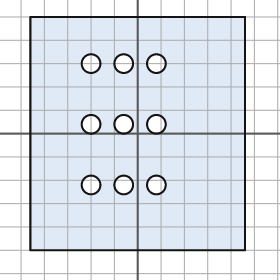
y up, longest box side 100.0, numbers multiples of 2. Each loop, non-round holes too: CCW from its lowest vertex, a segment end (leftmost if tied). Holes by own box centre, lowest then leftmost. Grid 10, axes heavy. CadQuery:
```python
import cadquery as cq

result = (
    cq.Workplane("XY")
    .moveTo(-46.0, -50.0)
    .lineTo(46.0, -50.0)
    .lineTo(46.0, 50.0)
    .lineTo(-46.0, 50.0)
    .close()
    .moveTo(-20.0, -22.0)
    .circle(4.0)
    .moveTo(-6.0, -22.0)
    .circle(4.0)
    .moveTo(8.0, -22.0)
    .circle(4.0)
    .moveTo(-20.0, 4.0)
    .circle(4.0)
    .moveTo(-6.0, 4.0)
    .circle(4.0)
    .moveTo(8.0, 4.0)
    .circle(4.0)
    .moveTo(-20.0, 30.0)
    .circle(4.0)
    .moveTo(-6.0, 30.0)
    .circle(4.0)
    .moveTo(8.0, 30.0)
    .circle(4.0)
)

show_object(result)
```